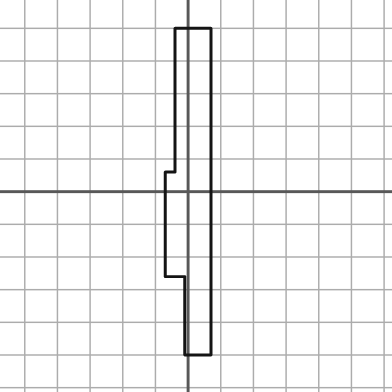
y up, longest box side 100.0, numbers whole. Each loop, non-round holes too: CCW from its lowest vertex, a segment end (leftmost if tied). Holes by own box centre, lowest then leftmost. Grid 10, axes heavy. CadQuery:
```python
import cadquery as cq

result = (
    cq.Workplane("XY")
    .moveTo(-1.0, -50.0)
    .lineTo(7.0, -50.0)
    .lineTo(7.0, 50.0)
    .lineTo(-4.0, 50.0)
    .lineTo(-4.0, 6.0)
    .lineTo(-7.0, 6.0)
    .lineTo(-7.0, -26.0)
    .lineTo(-1.0, -26.0)
    .close()
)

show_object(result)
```